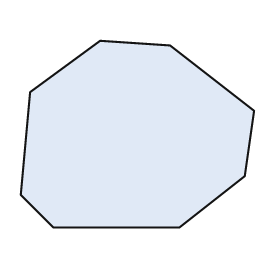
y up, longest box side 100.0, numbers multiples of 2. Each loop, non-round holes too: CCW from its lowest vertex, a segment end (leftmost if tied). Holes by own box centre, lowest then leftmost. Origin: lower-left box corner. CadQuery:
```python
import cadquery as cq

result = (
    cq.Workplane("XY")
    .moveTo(14.0, 0.0)
    .lineTo(68.0, 0.0)
    .lineTo(96.0, 22.0)
    .lineTo(100.0, 50.0)
    .lineTo(64.0, 78.0)
    .lineTo(34.0, 80.0)
    .lineTo(4.0, 58.0)
    .lineTo(0.0, 14.0)
    .close()
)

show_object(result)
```